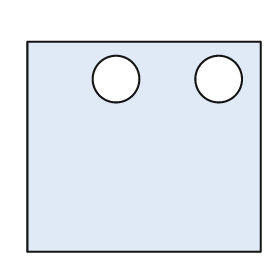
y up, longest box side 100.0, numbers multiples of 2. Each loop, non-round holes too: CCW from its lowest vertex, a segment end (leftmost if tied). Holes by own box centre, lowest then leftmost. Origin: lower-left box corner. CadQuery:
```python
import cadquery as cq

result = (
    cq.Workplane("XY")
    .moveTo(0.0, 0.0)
    .lineTo(100.0, 0.0)
    .lineTo(100.0, 90.0)
    .lineTo(0.0, 90.0)
    .close()
    .moveTo(38.0, 74.0)
    .circle(10.0)
    .moveTo(82.0, 74.0)
    .circle(10.0)
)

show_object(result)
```